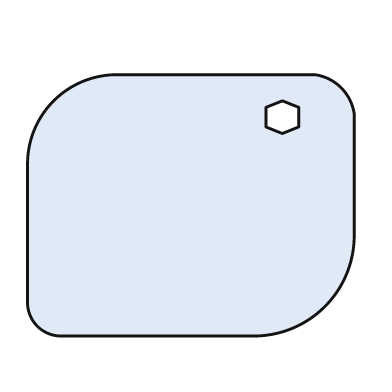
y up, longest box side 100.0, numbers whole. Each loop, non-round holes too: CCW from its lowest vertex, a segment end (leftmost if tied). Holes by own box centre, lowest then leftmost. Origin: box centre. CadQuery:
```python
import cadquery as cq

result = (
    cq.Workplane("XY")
    .moveTo(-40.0, -40.0)
    .lineTo(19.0, -40.0)
    .threePointArc((41.0, -31.0), (50.0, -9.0))
    .lineTo(50.0, 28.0)
    .threePointArc((46.0, 36.0), (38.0, 40.0))
    .lineTo(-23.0, 40.0)
    .threePointArc((-42.0, 32.0), (-50.0, 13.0))
    .lineTo(-50.0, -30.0)
    .threePointArc((-47.0, -37.0), (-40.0, -40.0))
    .close()
    .moveTo(28.0, 22.0)
    .lineTo(33.0, 24.0)
    .lineTo(33.0, 30.0)
    .lineTo(28.0, 32.0)
    .lineTo(23.0, 30.0)
    .lineTo(23.0, 24.0)
    .close()
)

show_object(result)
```